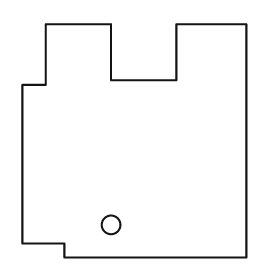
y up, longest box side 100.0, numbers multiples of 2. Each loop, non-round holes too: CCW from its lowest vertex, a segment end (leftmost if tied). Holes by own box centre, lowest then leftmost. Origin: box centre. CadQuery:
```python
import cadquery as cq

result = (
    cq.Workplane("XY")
    .moveTo(-30.0, -50.0)
    .lineTo(48.0, -50.0)
    .lineTo(48.0, 50.0)
    .lineTo(18.0, 50.0)
    .lineTo(18.0, 26.0)
    .lineTo(-10.0, 26.0)
    .lineTo(-10.0, 50.0)
    .lineTo(-38.0, 50.0)
    .lineTo(-38.0, 24.0)
    .lineTo(-48.0, 24.0)
    .lineTo(-48.0, -44.0)
    .lineTo(-30.0, -44.0)
    .close()
    .moveTo(-10.0, -36.0)
    .circle(4.0)
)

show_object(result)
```